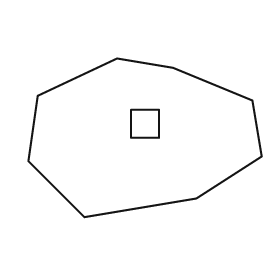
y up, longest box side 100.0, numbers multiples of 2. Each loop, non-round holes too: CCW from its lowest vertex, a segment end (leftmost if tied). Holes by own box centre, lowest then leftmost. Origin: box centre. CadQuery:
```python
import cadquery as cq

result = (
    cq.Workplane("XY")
    .moveTo(-26.0, -34.0)
    .lineTo(22.0, -26.0)
    .lineTo(50.0, -8.0)
    .lineTo(46.0, 16.0)
    .lineTo(12.0, 30.0)
    .lineTo(-12.0, 34.0)
    .lineTo(-46.0, 18.0)
    .lineTo(-50.0, -10.0)
    .close()
    .moveTo(-6.0, 0.0)
    .lineTo(6.0, 0.0)
    .lineTo(6.0, 12.0)
    .lineTo(-6.0, 12.0)
    .close()
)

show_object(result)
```